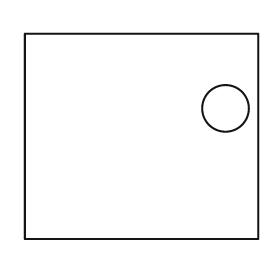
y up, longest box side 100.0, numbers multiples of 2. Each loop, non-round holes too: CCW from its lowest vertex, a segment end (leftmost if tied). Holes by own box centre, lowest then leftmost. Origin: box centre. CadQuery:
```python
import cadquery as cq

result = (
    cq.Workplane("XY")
    .moveTo(-50.0, -44.0)
    .lineTo(50.0, -44.0)
    .lineTo(50.0, 44.0)
    .lineTo(-50.0, 44.0)
    .close()
    .moveTo(36.0, 12.0)
    .circle(10.0)
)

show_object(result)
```